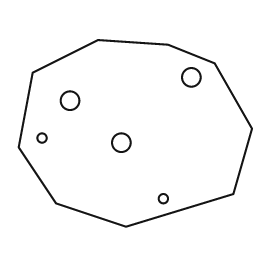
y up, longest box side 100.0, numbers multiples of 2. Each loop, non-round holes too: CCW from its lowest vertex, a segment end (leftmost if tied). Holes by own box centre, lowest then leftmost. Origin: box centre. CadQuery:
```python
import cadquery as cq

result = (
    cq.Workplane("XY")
    .moveTo(-4.0, -40.0)
    .lineTo(42.0, -26.0)
    .lineTo(50.0, 2.0)
    .lineTo(34.0, 30.0)
    .lineTo(14.0, 38.0)
    .lineTo(-16.0, 40.0)
    .lineTo(-44.0, 26.0)
    .lineTo(-50.0, -6.0)
    .lineTo(-34.0, -30.0)
    .close()
    .moveTo(12.0, -28.0)
    .circle(2.0)
    .moveTo(-6.0, -4.0)
    .circle(4.0)
    .moveTo(-40.0, -2.0)
    .circle(2.0)
    .moveTo(-28.0, 14.0)
    .circle(4.0)
    .moveTo(24.0, 24.0)
    .circle(4.0)
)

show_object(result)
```